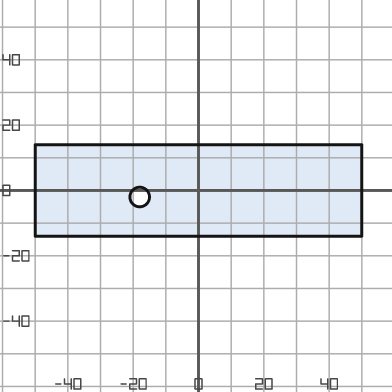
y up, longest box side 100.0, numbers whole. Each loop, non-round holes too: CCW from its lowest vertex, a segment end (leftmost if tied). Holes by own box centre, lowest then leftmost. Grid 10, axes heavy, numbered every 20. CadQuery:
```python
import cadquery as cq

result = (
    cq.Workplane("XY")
    .moveTo(-50.0, -14.0)
    .lineTo(50.0, -14.0)
    .lineTo(50.0, 14.0)
    .lineTo(-50.0, 14.0)
    .close()
    .moveTo(-18.0, -2.0)
    .circle(3.0)
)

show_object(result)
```